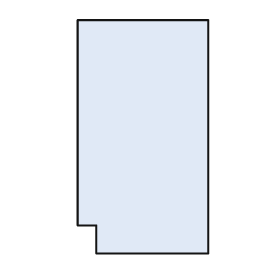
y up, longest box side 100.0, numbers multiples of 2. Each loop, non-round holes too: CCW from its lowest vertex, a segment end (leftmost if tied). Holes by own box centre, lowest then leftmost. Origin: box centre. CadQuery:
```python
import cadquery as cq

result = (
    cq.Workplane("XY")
    .moveTo(-20.0, -50.0)
    .lineTo(28.0, -50.0)
    .lineTo(28.0, 50.0)
    .lineTo(-28.0, 50.0)
    .lineTo(-28.0, -38.0)
    .lineTo(-20.0, -38.0)
    .close()
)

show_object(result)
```